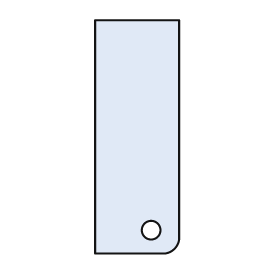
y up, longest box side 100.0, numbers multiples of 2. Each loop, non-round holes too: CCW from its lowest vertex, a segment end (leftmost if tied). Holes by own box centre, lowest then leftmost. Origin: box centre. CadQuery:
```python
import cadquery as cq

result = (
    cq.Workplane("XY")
    .moveTo(-18.0, -50.0)
    .lineTo(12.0, -50.0)
    .threePointArc((16.0, -48.0), (18.0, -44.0))
    .lineTo(18.0, 50.0)
    .lineTo(-18.0, 50.0)
    .close()
    .moveTo(6.0, -40.0)
    .circle(4.0)
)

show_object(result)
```